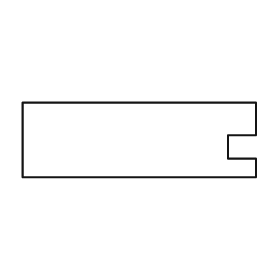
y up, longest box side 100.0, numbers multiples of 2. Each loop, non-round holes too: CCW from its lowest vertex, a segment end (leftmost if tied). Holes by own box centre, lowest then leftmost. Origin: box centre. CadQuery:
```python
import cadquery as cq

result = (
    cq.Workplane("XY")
    .moveTo(-50.0, -16.0)
    .lineTo(50.0, -16.0)
    .lineTo(50.0, -8.0)
    .lineTo(38.0, -8.0)
    .lineTo(38.0, 2.0)
    .lineTo(50.0, 2.0)
    .lineTo(50.0, 16.0)
    .lineTo(-50.0, 16.0)
    .close()
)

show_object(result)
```